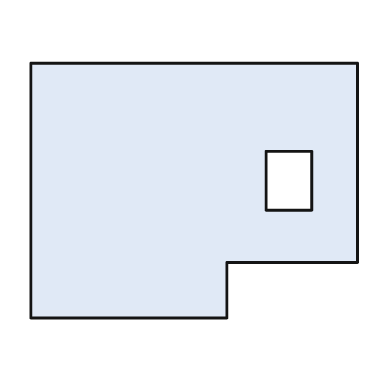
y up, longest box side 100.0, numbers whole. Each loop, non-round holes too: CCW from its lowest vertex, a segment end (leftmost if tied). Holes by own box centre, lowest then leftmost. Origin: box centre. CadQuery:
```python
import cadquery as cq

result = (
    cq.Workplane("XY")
    .moveTo(-50.0, -39.0)
    .lineTo(10.0, -39.0)
    .lineTo(10.0, -22.0)
    .lineTo(50.0, -22.0)
    .lineTo(50.0, 39.0)
    .lineTo(-50.0, 39.0)
    .close()
    .moveTo(22.0, -6.0)
    .lineTo(36.0, -6.0)
    .lineTo(36.0, 12.0)
    .lineTo(22.0, 12.0)
    .close()
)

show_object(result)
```